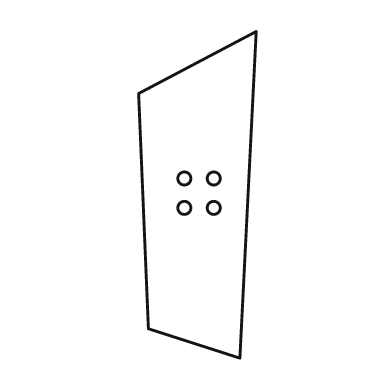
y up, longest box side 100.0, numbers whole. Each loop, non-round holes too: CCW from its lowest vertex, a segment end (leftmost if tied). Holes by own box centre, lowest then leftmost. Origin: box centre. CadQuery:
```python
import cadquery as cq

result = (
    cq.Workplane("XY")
    .moveTo(13.0, -50.0)
    .lineTo(18.0, 50.0)
    .lineTo(-18.0, 31.0)
    .lineTo(-15.0, -41.0)
    .close()
    .moveTo(-4.0, -4.0)
    .circle(2.0)
    .moveTo(5.0, -4.0)
    .circle(2.0)
    .moveTo(-4.0, 5.0)
    .circle(2.0)
    .moveTo(5.0, 5.0)
    .circle(2.0)
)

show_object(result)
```